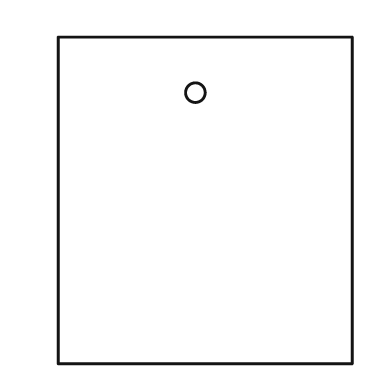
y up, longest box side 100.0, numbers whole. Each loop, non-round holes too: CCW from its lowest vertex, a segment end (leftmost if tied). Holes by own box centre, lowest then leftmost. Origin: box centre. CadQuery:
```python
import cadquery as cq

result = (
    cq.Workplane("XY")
    .moveTo(-45.0, -50.0)
    .lineTo(45.0, -50.0)
    .lineTo(45.0, 50.0)
    .lineTo(-45.0, 50.0)
    .close()
    .moveTo(-3.0, 33.0)
    .circle(3.0)
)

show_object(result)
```